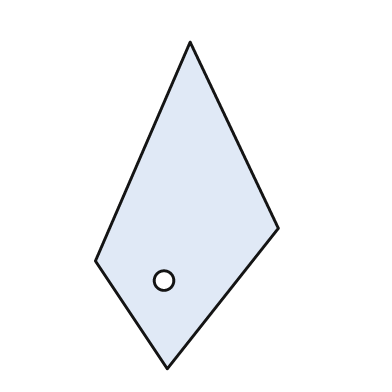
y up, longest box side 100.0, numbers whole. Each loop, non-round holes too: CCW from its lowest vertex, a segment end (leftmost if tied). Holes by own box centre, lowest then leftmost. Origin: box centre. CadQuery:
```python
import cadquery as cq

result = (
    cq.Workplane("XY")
    .moveTo(-6.0, -50.0)
    .lineTo(28.0, -7.0)
    .lineTo(1.0, 50.0)
    .lineTo(-28.0, -17.0)
    .close()
    .moveTo(-7.0, -23.0)
    .circle(3.0)
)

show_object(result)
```